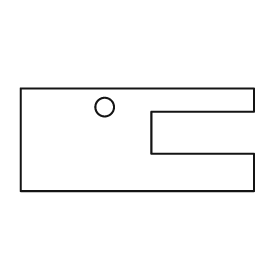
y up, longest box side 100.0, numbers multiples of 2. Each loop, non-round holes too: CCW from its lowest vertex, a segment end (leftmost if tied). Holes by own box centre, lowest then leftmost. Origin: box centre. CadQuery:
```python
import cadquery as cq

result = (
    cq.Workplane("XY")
    .moveTo(-50.0, -22.0)
    .lineTo(50.0, -22.0)
    .lineTo(50.0, -6.0)
    .lineTo(6.0, -6.0)
    .lineTo(6.0, 12.0)
    .lineTo(50.0, 12.0)
    .lineTo(50.0, 22.0)
    .lineTo(-50.0, 22.0)
    .close()
    .moveTo(-14.0, 14.0)
    .circle(4.0)
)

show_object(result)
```